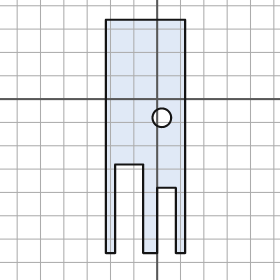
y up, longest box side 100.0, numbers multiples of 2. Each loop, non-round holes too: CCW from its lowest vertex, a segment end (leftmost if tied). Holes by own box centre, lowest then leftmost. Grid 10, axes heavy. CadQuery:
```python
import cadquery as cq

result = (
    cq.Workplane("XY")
    .moveTo(-22.0, -66.0)
    .lineTo(-18.0, -66.0)
    .lineTo(-18.0, -28.0)
    .lineTo(-6.0, -28.0)
    .lineTo(-6.0, -66.0)
    .lineTo(0.0, -66.0)
    .lineTo(0.0, -38.0)
    .lineTo(8.0, -38.0)
    .lineTo(8.0, -66.0)
    .lineTo(12.0, -66.0)
    .lineTo(12.0, 34.0)
    .lineTo(-22.0, 34.0)
    .close()
    .moveTo(2.0, -8.0)
    .circle(4.0)
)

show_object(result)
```